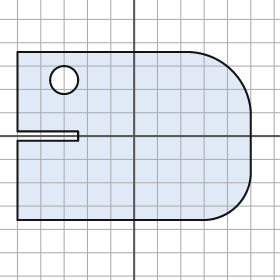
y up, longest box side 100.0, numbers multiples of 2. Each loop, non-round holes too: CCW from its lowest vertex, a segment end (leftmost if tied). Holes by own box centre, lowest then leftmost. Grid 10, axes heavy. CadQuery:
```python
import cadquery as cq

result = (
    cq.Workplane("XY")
    .moveTo(-50.0, -36.0)
    .lineTo(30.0, -36.0)
    .threePointArc((44.0, -30.0), (50.0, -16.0))
    .lineTo(50.0, 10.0)
    .threePointArc((42.0, 28.0), (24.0, 36.0))
    .lineTo(-50.0, 36.0)
    .lineTo(-50.0, 2.0)
    .lineTo(-24.0, 2.0)
    .lineTo(-24.0, -2.0)
    .lineTo(-50.0, -2.0)
    .close()
    .moveTo(-30.0, 24.0)
    .circle(6.0)
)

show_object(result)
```